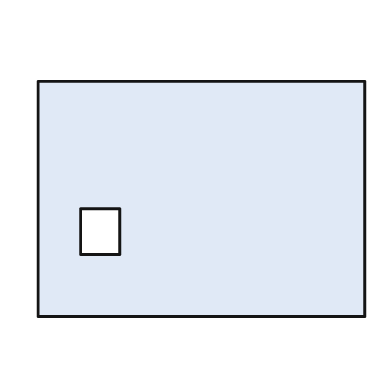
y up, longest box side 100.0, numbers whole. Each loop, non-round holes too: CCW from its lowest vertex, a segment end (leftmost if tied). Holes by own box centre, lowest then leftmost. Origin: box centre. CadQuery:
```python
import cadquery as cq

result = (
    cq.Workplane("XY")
    .moveTo(-50.0, -36.0)
    .lineTo(50.0, -36.0)
    .lineTo(50.0, 36.0)
    .lineTo(-50.0, 36.0)
    .close()
    .moveTo(-37.0, -17.0)
    .lineTo(-25.0, -17.0)
    .lineTo(-25.0, -3.0)
    .lineTo(-37.0, -3.0)
    .close()
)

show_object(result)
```